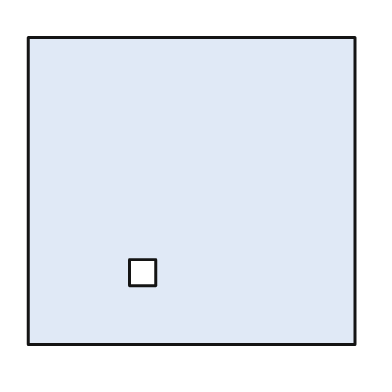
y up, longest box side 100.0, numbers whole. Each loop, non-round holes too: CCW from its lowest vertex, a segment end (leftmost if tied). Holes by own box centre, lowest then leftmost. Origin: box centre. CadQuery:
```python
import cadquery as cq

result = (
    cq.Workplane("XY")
    .moveTo(-50.0, -47.0)
    .lineTo(50.0, -47.0)
    .lineTo(50.0, 47.0)
    .lineTo(-50.0, 47.0)
    .close()
    .moveTo(-19.0, -29.0)
    .lineTo(-11.0, -29.0)
    .lineTo(-11.0, -21.0)
    .lineTo(-19.0, -21.0)
    .close()
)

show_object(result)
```